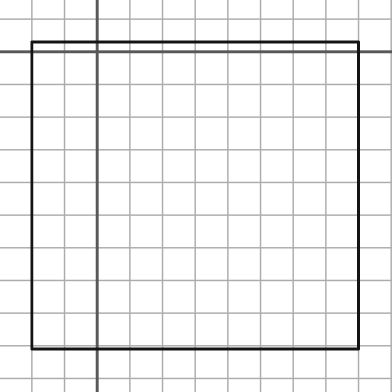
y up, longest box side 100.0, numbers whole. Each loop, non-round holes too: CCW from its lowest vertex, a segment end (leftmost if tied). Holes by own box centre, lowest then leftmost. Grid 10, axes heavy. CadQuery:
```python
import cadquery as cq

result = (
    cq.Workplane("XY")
    .moveTo(-20.0, -91.0)
    .lineTo(80.0, -91.0)
    .lineTo(80.0, 3.0)
    .lineTo(-20.0, 3.0)
    .close()
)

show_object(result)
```